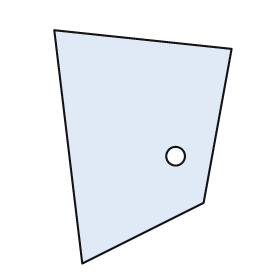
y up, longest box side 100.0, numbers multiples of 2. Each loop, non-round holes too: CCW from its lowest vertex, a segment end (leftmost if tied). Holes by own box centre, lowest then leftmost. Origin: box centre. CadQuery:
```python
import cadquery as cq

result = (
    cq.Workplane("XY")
    .moveTo(-26.0, -50.0)
    .lineTo(26.0, -24.0)
    .lineTo(38.0, 42.0)
    .lineTo(-38.0, 50.0)
    .close()
    .moveTo(14.0, -4.0)
    .circle(4.0)
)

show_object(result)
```